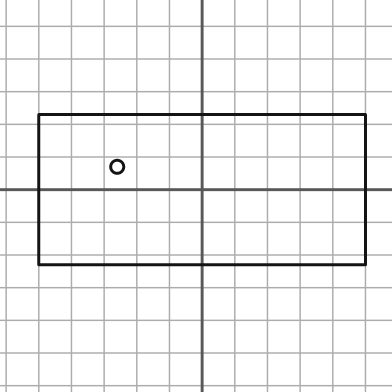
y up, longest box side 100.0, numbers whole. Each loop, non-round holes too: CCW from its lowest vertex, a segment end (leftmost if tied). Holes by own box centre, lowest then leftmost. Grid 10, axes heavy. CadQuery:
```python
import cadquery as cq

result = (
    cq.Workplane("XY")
    .moveTo(-50.0, -23.0)
    .lineTo(50.0, -23.0)
    .lineTo(50.0, 23.0)
    .lineTo(-50.0, 23.0)
    .close()
    .moveTo(-26.0, 7.0)
    .circle(2.0)
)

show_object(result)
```